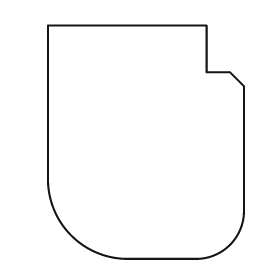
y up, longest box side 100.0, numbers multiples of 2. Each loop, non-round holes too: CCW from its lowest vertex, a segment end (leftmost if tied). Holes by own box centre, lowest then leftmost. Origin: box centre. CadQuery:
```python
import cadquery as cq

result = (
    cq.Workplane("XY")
    .moveTo(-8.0, -50.0)
    .lineTo(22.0, -50.0)
    .threePointArc((36.0, -44.0), (42.0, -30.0))
    .lineTo(42.0, 24.0)
    .lineTo(36.0, 30.0)
    .lineTo(26.0, 30.0)
    .lineTo(26.0, 50.0)
    .lineTo(-42.0, 50.0)
    .lineTo(-42.0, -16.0)
    .threePointArc((-32.0, -40.0), (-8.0, -50.0))
    .close()
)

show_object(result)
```